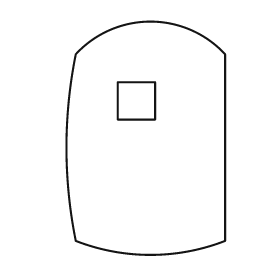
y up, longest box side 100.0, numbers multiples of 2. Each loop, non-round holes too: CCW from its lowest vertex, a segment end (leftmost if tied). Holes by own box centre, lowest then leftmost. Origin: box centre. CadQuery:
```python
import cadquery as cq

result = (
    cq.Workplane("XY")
    .moveTo(-30.0, -44.0)
    .threePointArc((2.0, -50.0), (34.0, -44.0))
    .lineTo(34.0, 36.0)
    .threePointArc((2.0, 50.0), (-30.0, 36.0))
    .threePointArc((-34.0, -4.0), (-30.0, -44.0))
    .close()
    .moveTo(-12.0, 8.0)
    .lineTo(4.0, 8.0)
    .lineTo(4.0, 24.0)
    .lineTo(-12.0, 24.0)
    .close()
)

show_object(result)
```